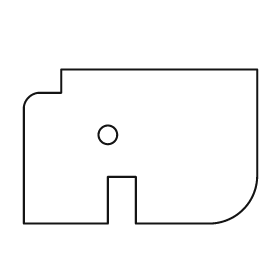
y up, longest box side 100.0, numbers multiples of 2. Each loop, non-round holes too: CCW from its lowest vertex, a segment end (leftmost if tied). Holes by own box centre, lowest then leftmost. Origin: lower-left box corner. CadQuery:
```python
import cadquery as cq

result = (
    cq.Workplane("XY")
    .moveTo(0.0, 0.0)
    .lineTo(36.0, 0.0)
    .lineTo(36.0, 20.0)
    .lineTo(48.0, 20.0)
    .lineTo(48.0, 0.0)
    .lineTo(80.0, 0.0)
    .threePointArc((94.0, 6.0), (100.0, 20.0))
    .lineTo(100.0, 66.0)
    .lineTo(16.0, 66.0)
    .lineTo(16.0, 56.0)
    .lineTo(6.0, 56.0)
    .threePointArc((2.0, 54.0), (0.0, 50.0))
    .close()
    .moveTo(36.0, 38.0)
    .circle(4.0)
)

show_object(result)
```